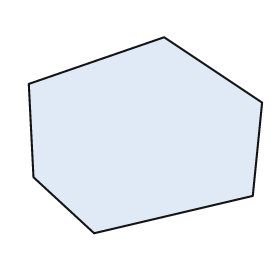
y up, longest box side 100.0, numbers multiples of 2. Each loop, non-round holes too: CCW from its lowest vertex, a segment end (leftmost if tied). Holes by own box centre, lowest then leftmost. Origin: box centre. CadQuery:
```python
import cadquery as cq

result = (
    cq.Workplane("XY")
    .moveTo(-22.0, -42.0)
    .lineTo(46.0, -26.0)
    .lineTo(50.0, 14.0)
    .lineTo(8.0, 42.0)
    .lineTo(-50.0, 22.0)
    .lineTo(-48.0, -18.0)
    .close()
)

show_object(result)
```